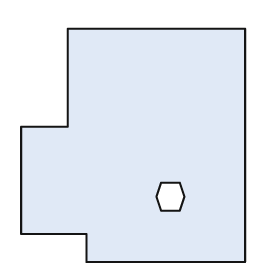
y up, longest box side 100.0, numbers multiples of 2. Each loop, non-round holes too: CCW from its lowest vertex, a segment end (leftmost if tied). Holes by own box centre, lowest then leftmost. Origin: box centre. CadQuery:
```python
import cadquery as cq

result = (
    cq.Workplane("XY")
    .moveTo(-20.0, -50.0)
    .lineTo(48.0, -50.0)
    .lineTo(48.0, 50.0)
    .lineTo(-28.0, 50.0)
    .lineTo(-28.0, 8.0)
    .lineTo(-48.0, 8.0)
    .lineTo(-48.0, -38.0)
    .lineTo(-20.0, -38.0)
    .close()
    .moveTo(12.0, -28.0)
    .lineTo(20.0, -28.0)
    .lineTo(22.0, -22.0)
    .lineTo(20.0, -16.0)
    .lineTo(12.0, -16.0)
    .lineTo(10.0, -22.0)
    .close()
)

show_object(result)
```